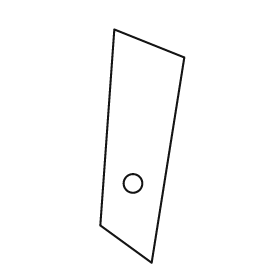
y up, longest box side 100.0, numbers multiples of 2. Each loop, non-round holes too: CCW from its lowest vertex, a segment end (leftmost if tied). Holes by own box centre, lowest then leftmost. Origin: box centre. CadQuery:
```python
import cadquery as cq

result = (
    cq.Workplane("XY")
    .moveTo(4.0, -50.0)
    .lineTo(18.0, 38.0)
    .lineTo(-12.0, 50.0)
    .lineTo(-18.0, -34.0)
    .close()
    .moveTo(-4.0, -16.0)
    .circle(4.0)
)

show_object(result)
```